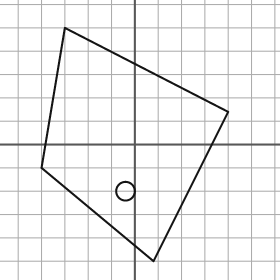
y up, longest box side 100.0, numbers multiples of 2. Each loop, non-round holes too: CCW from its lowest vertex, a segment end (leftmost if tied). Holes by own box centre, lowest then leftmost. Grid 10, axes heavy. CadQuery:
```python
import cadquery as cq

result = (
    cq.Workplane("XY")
    .moveTo(8.0, -50.0)
    .lineTo(40.0, 14.0)
    .lineTo(-30.0, 50.0)
    .lineTo(-40.0, -10.0)
    .close()
    .moveTo(-4.0, -20.0)
    .circle(4.0)
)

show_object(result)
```